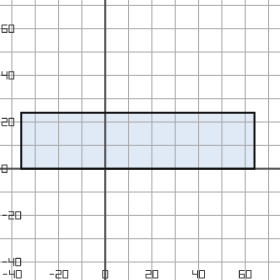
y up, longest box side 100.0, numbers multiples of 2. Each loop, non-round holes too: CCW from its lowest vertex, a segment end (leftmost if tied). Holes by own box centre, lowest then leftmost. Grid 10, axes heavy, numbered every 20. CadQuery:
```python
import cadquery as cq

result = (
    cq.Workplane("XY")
    .moveTo(-36.0, 0.0)
    .lineTo(64.0, 0.0)
    .lineTo(64.0, 24.0)
    .lineTo(-36.0, 24.0)
    .close()
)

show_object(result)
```